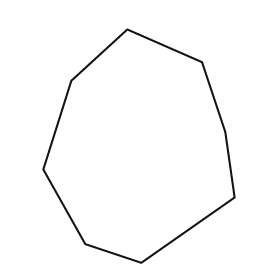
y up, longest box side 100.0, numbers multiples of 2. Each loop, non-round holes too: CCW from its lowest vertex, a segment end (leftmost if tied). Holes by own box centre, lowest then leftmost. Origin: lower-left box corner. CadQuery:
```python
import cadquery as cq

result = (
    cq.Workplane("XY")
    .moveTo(42.0, 0.0)
    .lineTo(82.0, 28.0)
    .lineTo(78.0, 56.0)
    .lineTo(68.0, 86.0)
    .lineTo(36.0, 100.0)
    .lineTo(12.0, 78.0)
    .lineTo(0.0, 40.0)
    .lineTo(18.0, 8.0)
    .close()
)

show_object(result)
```